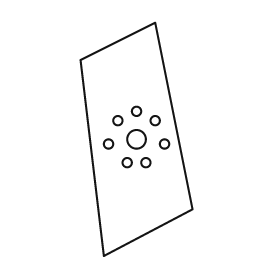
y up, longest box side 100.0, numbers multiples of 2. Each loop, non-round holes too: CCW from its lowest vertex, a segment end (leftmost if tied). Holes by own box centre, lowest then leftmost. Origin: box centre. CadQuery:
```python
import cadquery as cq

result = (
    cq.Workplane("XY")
    .moveTo(-14.0, -50.0)
    .lineTo(24.0, -30.0)
    .lineTo(8.0, 50.0)
    .lineTo(-24.0, 34.0)
    .close()
    .moveTo(-4.0, -10.0)
    .circle(2.0)
    .moveTo(4.0, -10.0)
    .circle(2.0)
    .moveTo(-12.0, -2.0)
    .circle(2.0)
    .moveTo(12.0, -2.0)
    .circle(2.0)
    .moveTo(0.0, 0.0)
    .circle(4.0)
    .moveTo(-8.0, 8.0)
    .circle(2.0)
    .moveTo(8.0, 8.0)
    .circle(2.0)
    .moveTo(0.0, 12.0)
    .circle(2.0)
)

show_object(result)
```